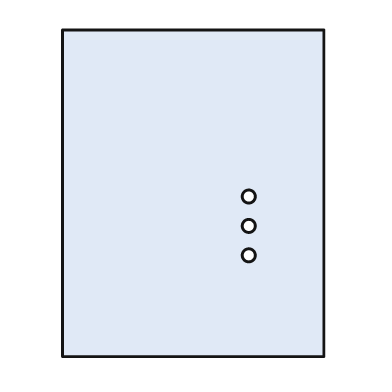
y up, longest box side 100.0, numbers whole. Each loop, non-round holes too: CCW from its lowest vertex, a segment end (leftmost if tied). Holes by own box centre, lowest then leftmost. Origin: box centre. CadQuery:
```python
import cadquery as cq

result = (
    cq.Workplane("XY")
    .moveTo(-40.0, -50.0)
    .lineTo(40.0, -50.0)
    .lineTo(40.0, 50.0)
    .lineTo(-40.0, 50.0)
    .close()
    .moveTo(17.0, -19.0)
    .circle(2.0)
    .moveTo(17.0, -10.0)
    .circle(2.0)
    .moveTo(17.0, -1.0)
    .circle(2.0)
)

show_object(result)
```